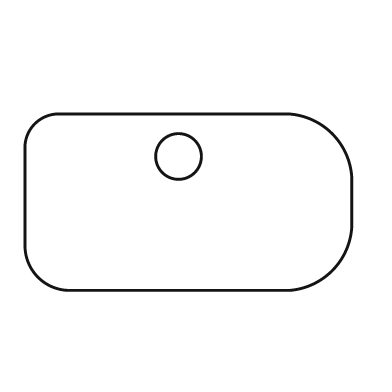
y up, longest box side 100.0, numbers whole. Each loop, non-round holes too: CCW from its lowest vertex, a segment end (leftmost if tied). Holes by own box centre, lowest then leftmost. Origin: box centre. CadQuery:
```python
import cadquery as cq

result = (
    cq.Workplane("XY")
    .moveTo(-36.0, -27.0)
    .lineTo(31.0, -27.0)
    .threePointArc((44.0, -21.0), (50.0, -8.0))
    .lineTo(50.0, 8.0)
    .threePointArc((44.0, 21.0), (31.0, 27.0))
    .lineTo(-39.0, 27.0)
    .threePointArc((-47.0, 24.0), (-50.0, 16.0))
    .lineTo(-50.0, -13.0)
    .threePointArc((-46.0, -23.0), (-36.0, -27.0))
    .close()
    .moveTo(-3.0, 14.0)
    .circle(7.0)
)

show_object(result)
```